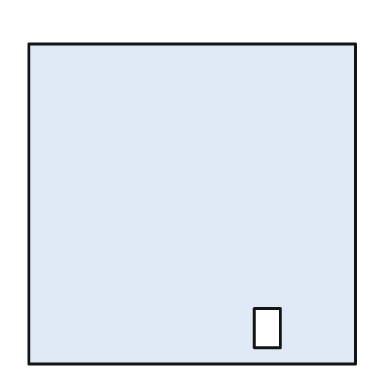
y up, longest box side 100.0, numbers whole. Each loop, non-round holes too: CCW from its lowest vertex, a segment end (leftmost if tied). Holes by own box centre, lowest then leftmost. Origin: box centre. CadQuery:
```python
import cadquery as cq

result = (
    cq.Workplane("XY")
    .moveTo(-50.0, -49.0)
    .lineTo(50.0, -49.0)
    .lineTo(50.0, 49.0)
    .lineTo(-50.0, 49.0)
    .close()
    .moveTo(19.0, -44.0)
    .lineTo(27.0, -44.0)
    .lineTo(27.0, -32.0)
    .lineTo(19.0, -32.0)
    .close()
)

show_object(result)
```